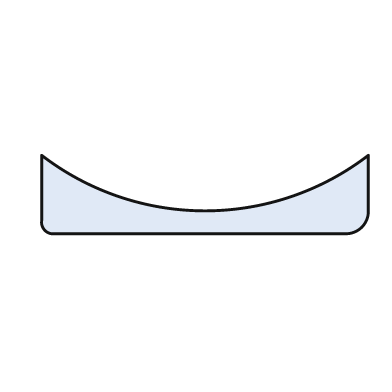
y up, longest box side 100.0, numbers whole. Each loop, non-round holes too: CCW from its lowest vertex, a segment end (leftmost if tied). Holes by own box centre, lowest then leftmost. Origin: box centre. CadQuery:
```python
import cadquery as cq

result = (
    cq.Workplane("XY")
    .moveTo(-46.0, -12.0)
    .lineTo(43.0, -12.0)
    .threePointArc((48.0, -10.0), (50.0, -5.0))
    .lineTo(50.0, 12.0)
    .threePointArc((0.0, -5.0), (-50.0, 12.0))
    .lineTo(-50.0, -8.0)
    .threePointArc((-49.0, -11.0), (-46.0, -12.0))
    .close()
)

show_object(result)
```